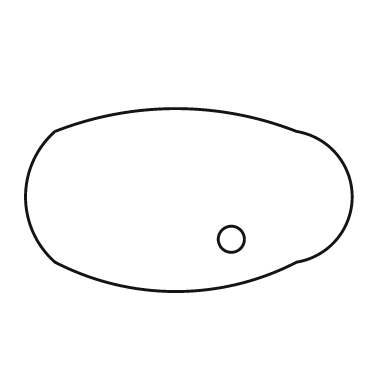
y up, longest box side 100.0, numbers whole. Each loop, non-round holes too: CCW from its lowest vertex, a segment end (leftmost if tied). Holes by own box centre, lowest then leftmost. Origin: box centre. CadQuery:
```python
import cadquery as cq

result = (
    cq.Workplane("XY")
    .moveTo(-41.0, -19.0)
    .threePointArc((-4.0, -28.0), (33.0, -19.0))
    .threePointArc((50.0, 1.0), (33.0, 21.0))
    .threePointArc((-4.0, 28.0), (-41.0, 21.0))
    .threePointArc((-50.0, 1.0), (-41.0, -19.0))
    .close()
    .moveTo(13.0, -12.0)
    .circle(4.0)
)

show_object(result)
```